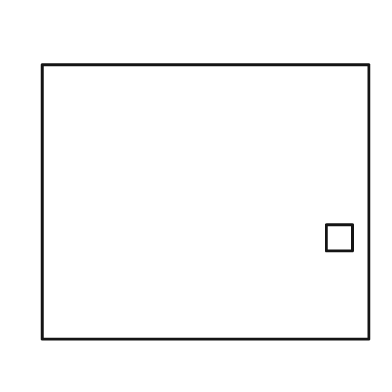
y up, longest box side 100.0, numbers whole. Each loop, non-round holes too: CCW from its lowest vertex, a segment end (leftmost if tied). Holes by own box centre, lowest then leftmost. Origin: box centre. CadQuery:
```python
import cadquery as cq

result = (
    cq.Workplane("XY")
    .moveTo(-50.0, -42.0)
    .lineTo(50.0, -42.0)
    .lineTo(50.0, 42.0)
    .lineTo(-50.0, 42.0)
    .close()
    .moveTo(37.0, -15.0)
    .lineTo(45.0, -15.0)
    .lineTo(45.0, -7.0)
    .lineTo(37.0, -7.0)
    .close()
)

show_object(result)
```